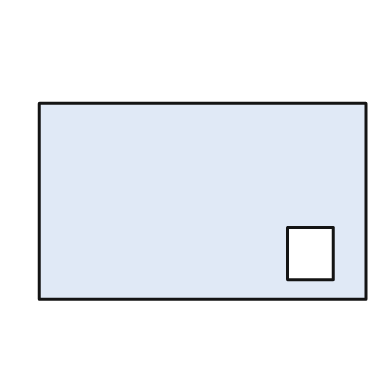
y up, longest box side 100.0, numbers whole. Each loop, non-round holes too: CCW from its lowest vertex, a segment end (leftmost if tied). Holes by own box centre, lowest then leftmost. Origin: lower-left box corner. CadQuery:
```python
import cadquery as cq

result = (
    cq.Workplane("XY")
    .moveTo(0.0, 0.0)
    .lineTo(100.0, 0.0)
    .lineTo(100.0, 60.0)
    .lineTo(0.0, 60.0)
    .close()
    .moveTo(76.0, 6.0)
    .lineTo(90.0, 6.0)
    .lineTo(90.0, 22.0)
    .lineTo(76.0, 22.0)
    .close()
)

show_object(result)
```